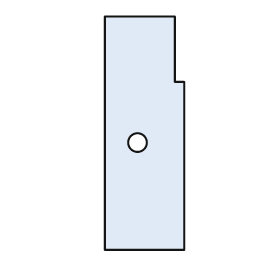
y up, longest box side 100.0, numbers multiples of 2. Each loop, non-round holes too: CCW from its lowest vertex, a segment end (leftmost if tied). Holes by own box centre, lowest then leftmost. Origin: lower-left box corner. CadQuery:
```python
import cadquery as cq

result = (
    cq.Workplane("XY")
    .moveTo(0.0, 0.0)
    .lineTo(34.0, 0.0)
    .lineTo(34.0, 72.0)
    .lineTo(30.0, 72.0)
    .lineTo(30.0, 100.0)
    .lineTo(0.0, 100.0)
    .close()
    .moveTo(14.0, 46.0)
    .circle(4.0)
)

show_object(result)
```